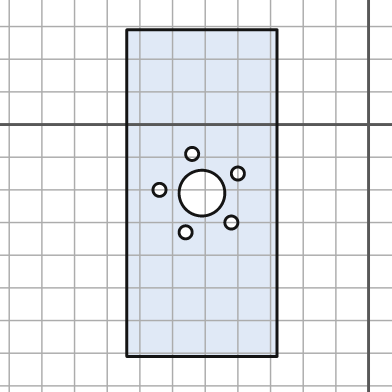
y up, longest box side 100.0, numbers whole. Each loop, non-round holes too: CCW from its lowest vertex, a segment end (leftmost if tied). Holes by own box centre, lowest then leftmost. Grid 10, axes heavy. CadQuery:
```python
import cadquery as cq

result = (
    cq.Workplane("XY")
    .moveTo(-74.0, -71.0)
    .lineTo(-28.0, -71.0)
    .lineTo(-28.0, 29.0)
    .lineTo(-74.0, 29.0)
    .close()
    .moveTo(-56.0, -33.0)
    .circle(2.0)
    .moveTo(-42.0, -30.0)
    .circle(2.0)
    .moveTo(-51.0, -21.0)
    .circle(7.0)
    .moveTo(-64.0, -20.0)
    .circle(2.0)
    .moveTo(-40.0, -15.0)
    .circle(2.0)
    .moveTo(-54.0, -9.0)
    .circle(2.0)
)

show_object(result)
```